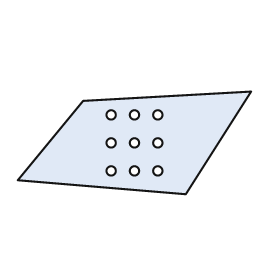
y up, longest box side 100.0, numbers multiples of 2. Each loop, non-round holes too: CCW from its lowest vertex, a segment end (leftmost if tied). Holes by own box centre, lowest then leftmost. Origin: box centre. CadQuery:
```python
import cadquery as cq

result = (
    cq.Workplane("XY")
    .moveTo(22.0, -22.0)
    .lineTo(50.0, 22.0)
    .lineTo(-22.0, 18.0)
    .lineTo(-50.0, -16.0)
    .close()
    .moveTo(-10.0, -12.0)
    .circle(2.0)
    .moveTo(0.0, -12.0)
    .circle(2.0)
    .moveTo(10.0, -12.0)
    .circle(2.0)
    .moveTo(-10.0, 0.0)
    .circle(2.0)
    .moveTo(0.0, 0.0)
    .circle(2.0)
    .moveTo(10.0, 0.0)
    .circle(2.0)
    .moveTo(-10.0, 12.0)
    .circle(2.0)
    .moveTo(0.0, 12.0)
    .circle(2.0)
    .moveTo(10.0, 12.0)
    .circle(2.0)
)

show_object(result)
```